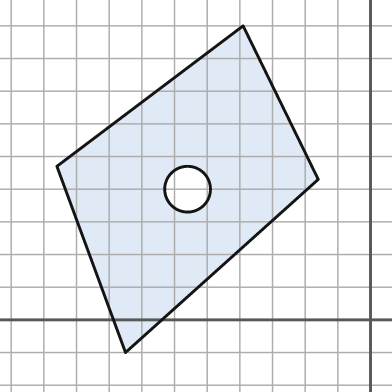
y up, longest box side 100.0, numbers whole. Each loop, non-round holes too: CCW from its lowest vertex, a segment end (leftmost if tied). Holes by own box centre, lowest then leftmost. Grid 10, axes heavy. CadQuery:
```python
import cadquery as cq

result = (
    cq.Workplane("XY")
    .moveTo(-75.0, -10.0)
    .lineTo(-16.0, 43.0)
    .lineTo(-39.0, 90.0)
    .lineTo(-96.0, 47.0)
    .close()
    .moveTo(-56.0, 40.0)
    .circle(7.0)
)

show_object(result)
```